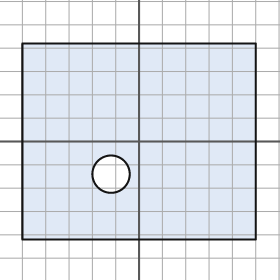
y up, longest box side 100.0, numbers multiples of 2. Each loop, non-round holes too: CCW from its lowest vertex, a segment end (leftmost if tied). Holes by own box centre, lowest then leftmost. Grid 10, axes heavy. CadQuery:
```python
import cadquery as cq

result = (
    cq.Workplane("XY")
    .moveTo(-50.0, -42.0)
    .lineTo(50.0, -42.0)
    .lineTo(50.0, 42.0)
    .lineTo(-50.0, 42.0)
    .close()
    .moveTo(-12.0, -14.0)
    .circle(8.0)
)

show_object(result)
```